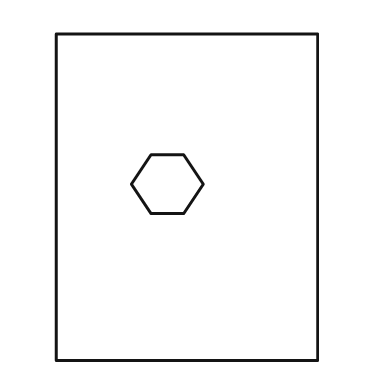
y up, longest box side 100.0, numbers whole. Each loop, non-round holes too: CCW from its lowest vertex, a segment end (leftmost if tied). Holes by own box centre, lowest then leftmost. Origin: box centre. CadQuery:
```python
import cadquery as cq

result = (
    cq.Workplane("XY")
    .moveTo(-40.0, -50.0)
    .lineTo(40.0, -50.0)
    .lineTo(40.0, 50.0)
    .lineTo(-40.0, 50.0)
    .close()
    .moveTo(-11.0, -5.0)
    .lineTo(-1.0, -5.0)
    .lineTo(5.0, 4.0)
    .lineTo(-1.0, 13.0)
    .lineTo(-11.0, 13.0)
    .lineTo(-17.0, 4.0)
    .close()
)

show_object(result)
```